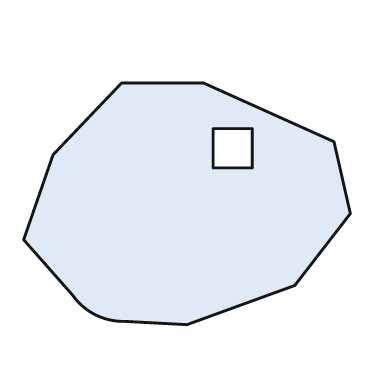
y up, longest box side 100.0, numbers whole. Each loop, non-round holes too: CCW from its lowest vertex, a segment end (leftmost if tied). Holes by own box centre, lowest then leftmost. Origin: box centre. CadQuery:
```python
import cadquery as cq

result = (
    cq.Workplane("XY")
    .moveTo(0.0, -37.0)
    .lineTo(33.0, -25.0)
    .lineTo(50.0, -3.0)
    .lineTo(45.0, 19.0)
    .lineTo(5.0, 37.0)
    .lineTo(-20.0, 37.0)
    .lineTo(-41.0, 15.0)
    .lineTo(-50.0, -11.0)
    .lineTo(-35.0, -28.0)
    .threePointArc((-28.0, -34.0), (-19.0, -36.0))
    .close()
    .moveTo(8.0, 11.0)
    .lineTo(20.0, 11.0)
    .lineTo(20.0, 23.0)
    .lineTo(8.0, 23.0)
    .close()
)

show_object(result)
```